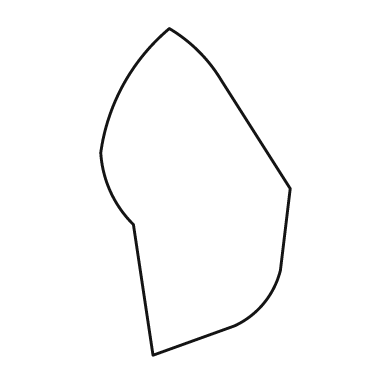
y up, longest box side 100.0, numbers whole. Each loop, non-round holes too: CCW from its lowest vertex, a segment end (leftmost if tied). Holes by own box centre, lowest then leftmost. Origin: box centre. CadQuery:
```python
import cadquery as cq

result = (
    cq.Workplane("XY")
    .moveTo(-13.0, -50.0)
    .lineTo(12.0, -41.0)
    .threePointArc((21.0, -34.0), (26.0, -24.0))
    .lineTo(29.0, 1.0)
    .lineTo(8.0, 34.0)
    .threePointArc((1.0, 43.0), (-8.0, 50.0))
    .threePointArc((-22.0, 33.0), (-29.0, 12.0))
    .threePointArc((-26.0, 0.0), (-19.0, -10.0))
    .close()
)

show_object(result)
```